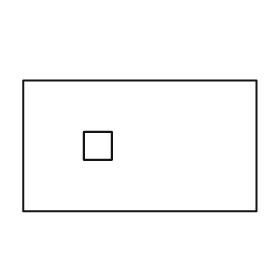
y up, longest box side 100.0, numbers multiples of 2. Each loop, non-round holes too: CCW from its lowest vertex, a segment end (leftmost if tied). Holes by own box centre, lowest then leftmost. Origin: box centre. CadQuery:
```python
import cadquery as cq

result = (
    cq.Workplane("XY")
    .moveTo(-50.0, -28.0)
    .lineTo(50.0, -28.0)
    .lineTo(50.0, 28.0)
    .lineTo(-50.0, 28.0)
    .close()
    .moveTo(-24.0, -6.0)
    .lineTo(-12.0, -6.0)
    .lineTo(-12.0, 6.0)
    .lineTo(-24.0, 6.0)
    .close()
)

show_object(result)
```